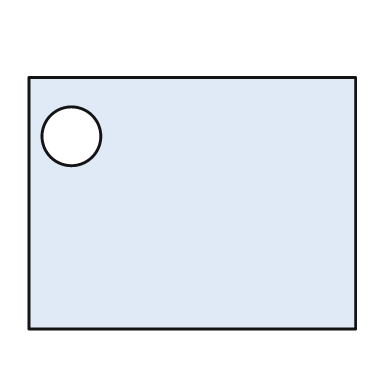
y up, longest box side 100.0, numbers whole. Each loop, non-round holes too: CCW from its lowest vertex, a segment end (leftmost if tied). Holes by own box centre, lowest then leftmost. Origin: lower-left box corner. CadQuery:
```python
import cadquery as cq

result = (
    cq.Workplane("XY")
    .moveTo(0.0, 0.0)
    .lineTo(100.0, 0.0)
    .lineTo(100.0, 77.0)
    .lineTo(0.0, 77.0)
    .close()
    .moveTo(13.0, 59.0)
    .circle(9.0)
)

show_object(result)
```